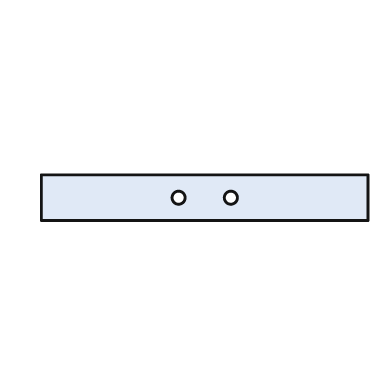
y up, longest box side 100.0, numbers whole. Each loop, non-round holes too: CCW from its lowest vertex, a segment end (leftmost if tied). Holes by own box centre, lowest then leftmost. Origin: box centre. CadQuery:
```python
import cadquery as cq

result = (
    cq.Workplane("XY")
    .moveTo(-50.0, -7.0)
    .lineTo(50.0, -7.0)
    .lineTo(50.0, 7.0)
    .lineTo(-50.0, 7.0)
    .close()
    .moveTo(-8.0, 0.0)
    .circle(2.0)
    .moveTo(8.0, 0.0)
    .circle(2.0)
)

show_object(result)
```